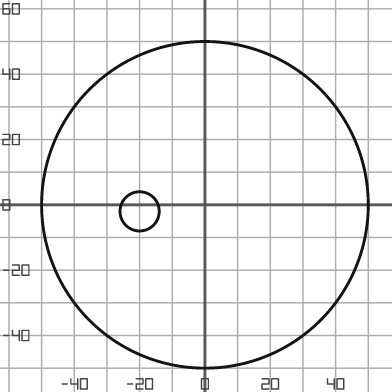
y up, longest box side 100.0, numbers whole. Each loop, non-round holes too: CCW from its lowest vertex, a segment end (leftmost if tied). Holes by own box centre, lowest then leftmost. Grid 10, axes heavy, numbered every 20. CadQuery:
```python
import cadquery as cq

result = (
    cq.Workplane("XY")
    .moveTo(0.0, 0.0)
    .circle(50.0)
    .moveTo(-20.0, -2.0)
    .circle(6.0)
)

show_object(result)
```